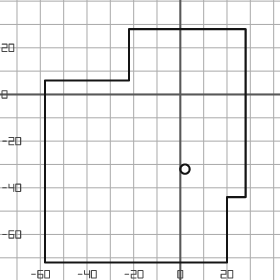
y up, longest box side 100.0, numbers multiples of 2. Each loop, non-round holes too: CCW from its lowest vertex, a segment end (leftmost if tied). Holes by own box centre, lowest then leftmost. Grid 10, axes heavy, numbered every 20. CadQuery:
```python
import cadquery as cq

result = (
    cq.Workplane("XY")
    .moveTo(-58.0, -72.0)
    .lineTo(20.0, -72.0)
    .lineTo(20.0, -44.0)
    .lineTo(28.0, -44.0)
    .lineTo(28.0, 28.0)
    .lineTo(-22.0, 28.0)
    .lineTo(-22.0, 6.0)
    .lineTo(-58.0, 6.0)
    .close()
    .moveTo(2.0, -32.0)
    .circle(2.0)
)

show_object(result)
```